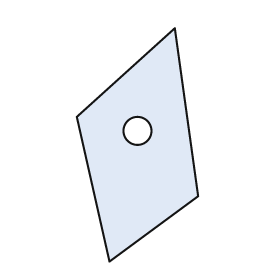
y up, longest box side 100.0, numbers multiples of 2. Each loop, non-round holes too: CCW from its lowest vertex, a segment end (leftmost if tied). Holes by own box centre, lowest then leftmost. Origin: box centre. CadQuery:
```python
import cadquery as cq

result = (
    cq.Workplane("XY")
    .moveTo(-12.0, -50.0)
    .lineTo(26.0, -22.0)
    .lineTo(16.0, 50.0)
    .lineTo(-26.0, 12.0)
    .close()
    .moveTo(0.0, 6.0)
    .circle(6.0)
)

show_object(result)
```